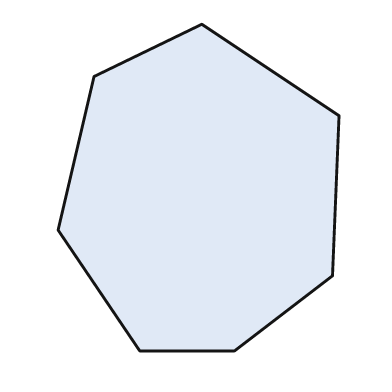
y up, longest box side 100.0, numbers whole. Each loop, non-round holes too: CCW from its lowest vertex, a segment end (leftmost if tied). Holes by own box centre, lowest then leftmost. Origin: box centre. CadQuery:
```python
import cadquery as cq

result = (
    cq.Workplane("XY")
    .moveTo(-18.0, -50.0)
    .lineTo(11.0, -50.0)
    .lineTo(41.0, -27.0)
    .lineTo(43.0, 22.0)
    .lineTo(1.0, 50.0)
    .lineTo(-32.0, 34.0)
    .lineTo(-43.0, -13.0)
    .close()
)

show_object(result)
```